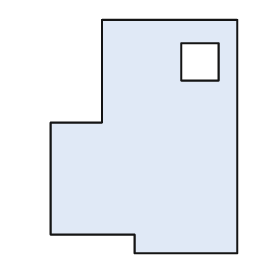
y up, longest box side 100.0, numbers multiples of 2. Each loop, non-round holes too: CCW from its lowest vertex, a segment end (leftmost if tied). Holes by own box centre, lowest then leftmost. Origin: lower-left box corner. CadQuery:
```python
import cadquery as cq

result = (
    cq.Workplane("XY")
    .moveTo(36.0, 0.0)
    .lineTo(80.0, 0.0)
    .lineTo(80.0, 100.0)
    .lineTo(22.0, 100.0)
    .lineTo(22.0, 56.0)
    .lineTo(0.0, 56.0)
    .lineTo(0.0, 8.0)
    .lineTo(36.0, 8.0)
    .close()
    .moveTo(56.0, 74.0)
    .lineTo(72.0, 74.0)
    .lineTo(72.0, 90.0)
    .lineTo(56.0, 90.0)
    .close()
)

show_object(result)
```